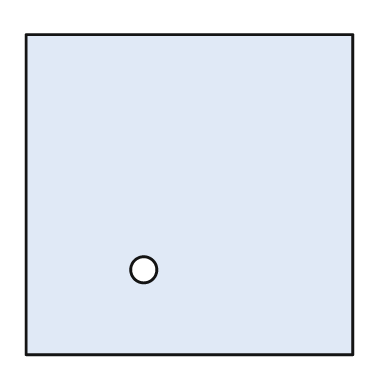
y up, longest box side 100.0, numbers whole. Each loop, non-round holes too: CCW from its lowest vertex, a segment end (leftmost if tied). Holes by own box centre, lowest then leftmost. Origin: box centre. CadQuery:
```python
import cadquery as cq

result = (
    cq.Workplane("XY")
    .moveTo(-50.0, -49.0)
    .lineTo(50.0, -49.0)
    .lineTo(50.0, 49.0)
    .lineTo(-50.0, 49.0)
    .close()
    .moveTo(-14.0, -23.0)
    .circle(4.0)
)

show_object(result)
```